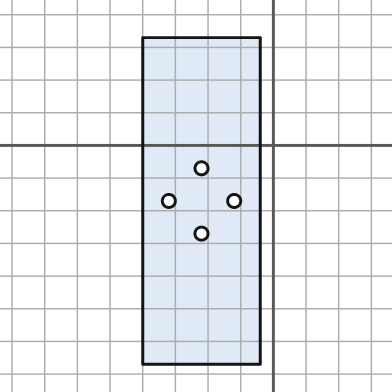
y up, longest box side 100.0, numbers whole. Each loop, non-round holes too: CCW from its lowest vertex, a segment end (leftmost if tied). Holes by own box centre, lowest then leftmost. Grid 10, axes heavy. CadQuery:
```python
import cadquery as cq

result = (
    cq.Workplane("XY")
    .moveTo(-40.0, -67.0)
    .lineTo(-4.0, -67.0)
    .lineTo(-4.0, 33.0)
    .lineTo(-40.0, 33.0)
    .close()
    .moveTo(-22.0, -27.0)
    .circle(2.0)
    .moveTo(-32.0, -17.0)
    .circle(2.0)
    .moveTo(-12.0, -17.0)
    .circle(2.0)
    .moveTo(-22.0, -7.0)
    .circle(2.0)
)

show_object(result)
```